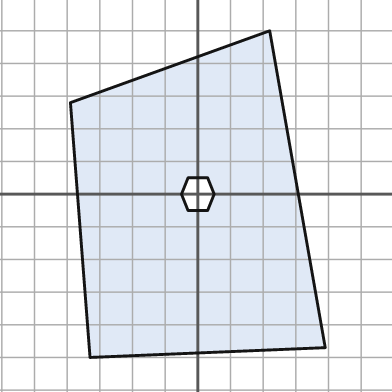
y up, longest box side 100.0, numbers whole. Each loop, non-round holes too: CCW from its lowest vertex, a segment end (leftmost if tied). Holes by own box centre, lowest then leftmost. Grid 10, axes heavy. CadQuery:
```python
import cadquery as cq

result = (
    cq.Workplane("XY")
    .moveTo(-33.0, -50.0)
    .lineTo(39.0, -47.0)
    .lineTo(22.0, 50.0)
    .lineTo(-39.0, 28.0)
    .close()
    .moveTo(-3.0, -5.0)
    .lineTo(3.0, -5.0)
    .lineTo(5.0, 0.0)
    .lineTo(3.0, 5.0)
    .lineTo(-3.0, 5.0)
    .lineTo(-5.0, 0.0)
    .close()
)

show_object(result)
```